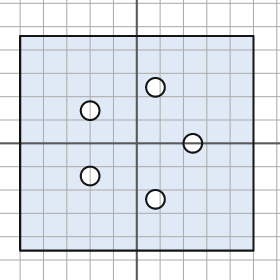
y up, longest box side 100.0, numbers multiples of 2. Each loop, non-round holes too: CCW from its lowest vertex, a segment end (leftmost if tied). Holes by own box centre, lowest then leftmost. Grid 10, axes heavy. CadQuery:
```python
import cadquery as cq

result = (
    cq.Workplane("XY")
    .moveTo(-50.0, -46.0)
    .lineTo(50.0, -46.0)
    .lineTo(50.0, 46.0)
    .lineTo(-50.0, 46.0)
    .close()
    .moveTo(8.0, -24.0)
    .circle(4.0)
    .moveTo(-20.0, -14.0)
    .circle(4.0)
    .moveTo(24.0, 0.0)
    .circle(4.0)
    .moveTo(-20.0, 14.0)
    .circle(4.0)
    .moveTo(8.0, 24.0)
    .circle(4.0)
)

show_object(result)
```